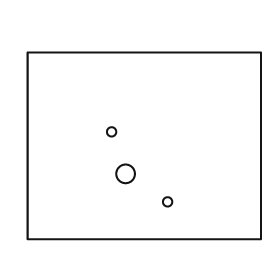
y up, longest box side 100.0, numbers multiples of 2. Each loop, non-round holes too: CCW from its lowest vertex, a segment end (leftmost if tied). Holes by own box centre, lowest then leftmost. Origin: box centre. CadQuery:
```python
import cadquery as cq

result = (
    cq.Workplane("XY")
    .moveTo(-50.0, -40.0)
    .lineTo(50.0, -40.0)
    .lineTo(50.0, 40.0)
    .lineTo(-50.0, 40.0)
    .close()
    .moveTo(10.0, -24.0)
    .circle(2.0)
    .moveTo(-8.0, -12.0)
    .circle(4.0)
    .moveTo(-14.0, 6.0)
    .circle(2.0)
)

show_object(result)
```